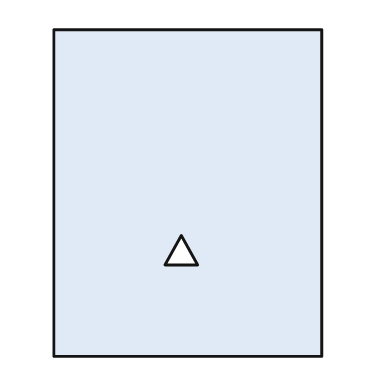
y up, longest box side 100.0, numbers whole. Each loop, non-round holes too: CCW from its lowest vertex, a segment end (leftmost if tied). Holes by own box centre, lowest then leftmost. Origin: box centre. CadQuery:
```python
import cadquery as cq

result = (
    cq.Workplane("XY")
    .moveTo(-41.0, -50.0)
    .lineTo(41.0, -50.0)
    .lineTo(41.0, 50.0)
    .lineTo(-41.0, 50.0)
    .close()
    .moveTo(-7.0, -22.0)
    .lineTo(3.0, -22.0)
    .lineTo(-2.0, -13.0)
    .close()
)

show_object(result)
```